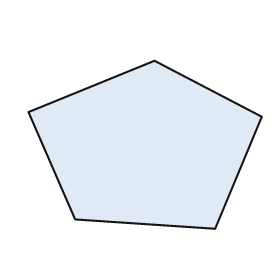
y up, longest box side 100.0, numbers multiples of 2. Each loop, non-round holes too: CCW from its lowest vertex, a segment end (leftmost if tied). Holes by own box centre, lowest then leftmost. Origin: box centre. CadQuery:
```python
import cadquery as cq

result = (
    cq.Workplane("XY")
    .moveTo(30.0, -36.0)
    .lineTo(50.0, 12.0)
    .lineTo(4.0, 36.0)
    .lineTo(-50.0, 14.0)
    .lineTo(-30.0, -32.0)
    .close()
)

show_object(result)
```